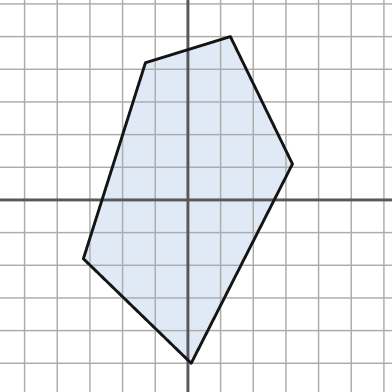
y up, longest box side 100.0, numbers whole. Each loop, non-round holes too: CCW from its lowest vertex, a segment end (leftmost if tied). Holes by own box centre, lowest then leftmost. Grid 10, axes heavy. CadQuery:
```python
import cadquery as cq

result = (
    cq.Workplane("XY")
    .moveTo(1.0, -50.0)
    .lineTo(32.0, 11.0)
    .lineTo(13.0, 50.0)
    .lineTo(-13.0, 42.0)
    .lineTo(-32.0, -18.0)
    .close()
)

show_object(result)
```